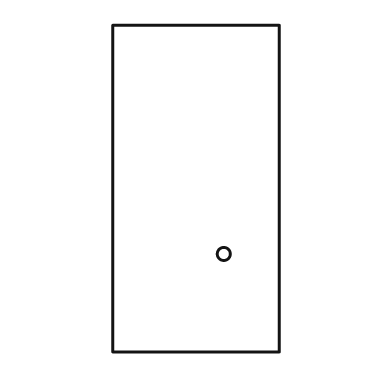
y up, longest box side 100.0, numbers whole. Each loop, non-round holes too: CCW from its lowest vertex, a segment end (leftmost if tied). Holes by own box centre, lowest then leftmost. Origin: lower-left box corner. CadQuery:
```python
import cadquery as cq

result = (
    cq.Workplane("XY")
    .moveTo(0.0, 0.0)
    .lineTo(51.0, 0.0)
    .lineTo(51.0, 100.0)
    .lineTo(0.0, 100.0)
    .close()
    .moveTo(34.0, 30.0)
    .circle(2.0)
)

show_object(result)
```